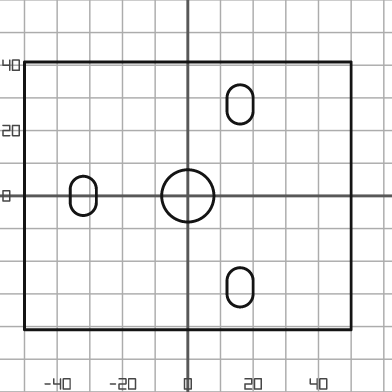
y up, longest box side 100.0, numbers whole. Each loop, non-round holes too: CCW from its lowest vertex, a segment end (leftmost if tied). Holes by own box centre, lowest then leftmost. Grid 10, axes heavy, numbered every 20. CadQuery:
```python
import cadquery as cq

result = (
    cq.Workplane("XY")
    .moveTo(-50.0, -41.0)
    .lineTo(50.0, -41.0)
    .lineTo(50.0, 41.0)
    .lineTo(-50.0, 41.0)
    .close()
    .moveTo(12.0, -30.0)
    .threePointArc((16.0, -34.0), (20.0, -30.0))
    .lineTo(20.0, -26.0)
    .threePointArc((16.0, -22.0), (12.0, -26.0))
    .close()
    .moveTo(-36.0, -2.0)
    .threePointArc((-32.0, -6.0), (-28.0, -2.0))
    .lineTo(-28.0, 2.0)
    .threePointArc((-32.0, 6.0), (-36.0, 2.0))
    .close()
    .moveTo(0.0, 0.0)
    .circle(8.0)
    .moveTo(12.0, 26.0)
    .threePointArc((16.0, 22.0), (20.0, 26.0))
    .lineTo(20.0, 30.0)
    .threePointArc((16.0, 34.0), (12.0, 30.0))
    .close()
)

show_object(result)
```